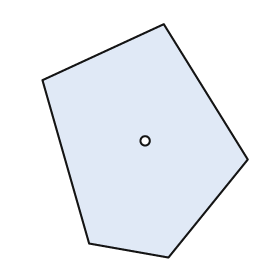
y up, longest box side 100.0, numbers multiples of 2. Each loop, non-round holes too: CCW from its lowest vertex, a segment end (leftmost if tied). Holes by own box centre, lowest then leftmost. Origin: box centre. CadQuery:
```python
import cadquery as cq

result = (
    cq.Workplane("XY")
    .moveTo(10.0, -50.0)
    .lineTo(44.0, -8.0)
    .lineTo(8.0, 50.0)
    .lineTo(-44.0, 26.0)
    .lineTo(-24.0, -44.0)
    .close()
    .moveTo(0.0, 0.0)
    .circle(2.0)
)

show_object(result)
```